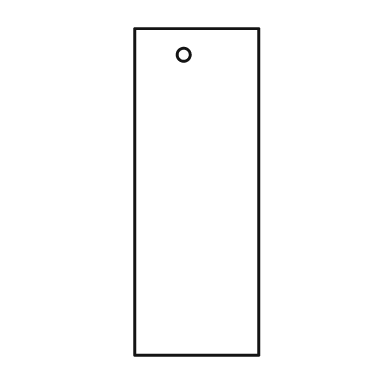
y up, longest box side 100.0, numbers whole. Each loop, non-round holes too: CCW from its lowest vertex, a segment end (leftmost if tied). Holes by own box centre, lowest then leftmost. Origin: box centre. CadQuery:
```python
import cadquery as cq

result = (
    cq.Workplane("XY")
    .moveTo(-19.0, -50.0)
    .lineTo(19.0, -50.0)
    .lineTo(19.0, 50.0)
    .lineTo(-19.0, 50.0)
    .close()
    .moveTo(-4.0, 42.0)
    .circle(2.0)
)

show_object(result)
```